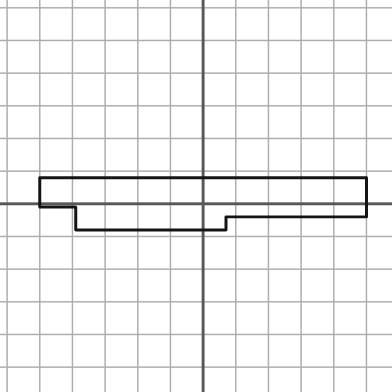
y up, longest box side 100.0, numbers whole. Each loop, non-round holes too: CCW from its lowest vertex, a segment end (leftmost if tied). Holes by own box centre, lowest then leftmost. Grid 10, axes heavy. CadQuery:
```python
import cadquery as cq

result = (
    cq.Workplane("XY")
    .moveTo(-39.0, -8.0)
    .lineTo(7.0, -8.0)
    .lineTo(7.0, -4.0)
    .lineTo(50.0, -4.0)
    .lineTo(50.0, 8.0)
    .lineTo(-50.0, 8.0)
    .lineTo(-50.0, -1.0)
    .lineTo(-39.0, -1.0)
    .close()
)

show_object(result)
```